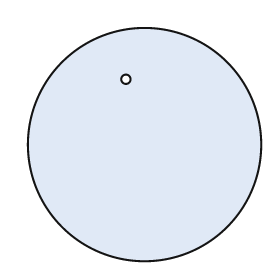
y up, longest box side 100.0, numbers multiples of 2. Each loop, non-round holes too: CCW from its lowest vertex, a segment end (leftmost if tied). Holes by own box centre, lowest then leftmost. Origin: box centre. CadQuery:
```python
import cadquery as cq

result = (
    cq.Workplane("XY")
    .moveTo(0.0, 0.0)
    .circle(50.0)
    .moveTo(-8.0, 28.0)
    .circle(2.0)
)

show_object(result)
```